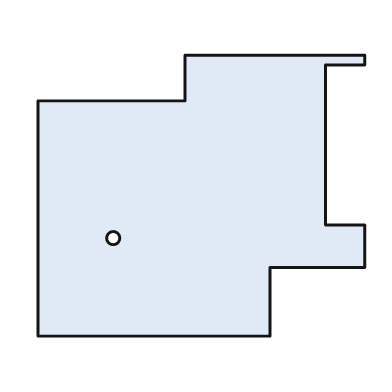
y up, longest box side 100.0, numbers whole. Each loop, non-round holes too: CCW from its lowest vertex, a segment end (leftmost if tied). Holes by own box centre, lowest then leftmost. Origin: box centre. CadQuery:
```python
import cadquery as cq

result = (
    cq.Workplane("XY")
    .moveTo(-50.0, -43.0)
    .lineTo(21.0, -43.0)
    .lineTo(21.0, -22.0)
    .lineTo(50.0, -22.0)
    .lineTo(50.0, -9.0)
    .lineTo(38.0, -9.0)
    .lineTo(38.0, 40.0)
    .lineTo(50.0, 40.0)
    .lineTo(50.0, 43.0)
    .lineTo(-5.0, 43.0)
    .lineTo(-5.0, 29.0)
    .lineTo(-50.0, 29.0)
    .close()
    .moveTo(-27.0, -13.0)
    .circle(2.0)
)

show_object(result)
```